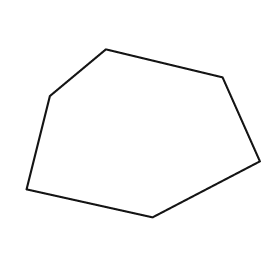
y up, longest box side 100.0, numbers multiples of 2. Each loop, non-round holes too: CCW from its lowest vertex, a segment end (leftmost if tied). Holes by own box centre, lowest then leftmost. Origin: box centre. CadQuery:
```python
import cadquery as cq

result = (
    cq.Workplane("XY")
    .moveTo(4.0, -36.0)
    .lineTo(50.0, -12.0)
    .lineTo(34.0, 24.0)
    .lineTo(-16.0, 36.0)
    .lineTo(-40.0, 16.0)
    .lineTo(-50.0, -24.0)
    .close()
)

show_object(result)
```